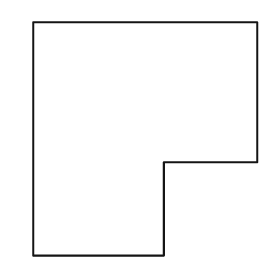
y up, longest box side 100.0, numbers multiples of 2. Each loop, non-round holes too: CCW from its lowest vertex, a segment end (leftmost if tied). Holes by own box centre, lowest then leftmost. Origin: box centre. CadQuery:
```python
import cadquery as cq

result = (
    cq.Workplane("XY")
    .moveTo(-48.0, -50.0)
    .lineTo(8.0, -50.0)
    .lineTo(8.0, -10.0)
    .lineTo(48.0, -10.0)
    .lineTo(48.0, 50.0)
    .lineTo(-48.0, 50.0)
    .close()
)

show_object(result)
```